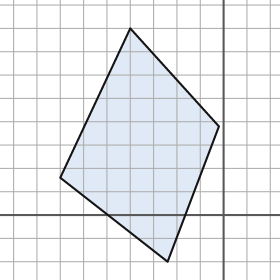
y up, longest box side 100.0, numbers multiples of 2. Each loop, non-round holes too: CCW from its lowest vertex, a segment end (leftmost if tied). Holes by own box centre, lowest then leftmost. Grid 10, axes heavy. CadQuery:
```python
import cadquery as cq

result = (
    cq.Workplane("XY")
    .moveTo(-24.0, -20.0)
    .lineTo(-2.0, 38.0)
    .lineTo(-40.0, 80.0)
    .lineTo(-70.0, 16.0)
    .close()
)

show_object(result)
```